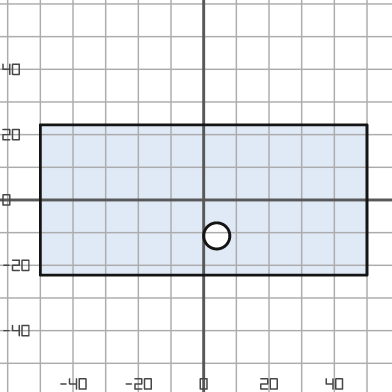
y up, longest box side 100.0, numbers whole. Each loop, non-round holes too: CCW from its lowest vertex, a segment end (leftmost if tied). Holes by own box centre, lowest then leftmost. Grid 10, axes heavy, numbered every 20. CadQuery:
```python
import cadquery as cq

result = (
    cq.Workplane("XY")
    .moveTo(-50.0, -23.0)
    .lineTo(50.0, -23.0)
    .lineTo(50.0, 23.0)
    .lineTo(-50.0, 23.0)
    .close()
    .moveTo(4.0, -11.0)
    .circle(4.0)
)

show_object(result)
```